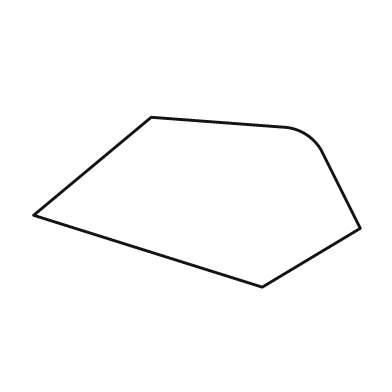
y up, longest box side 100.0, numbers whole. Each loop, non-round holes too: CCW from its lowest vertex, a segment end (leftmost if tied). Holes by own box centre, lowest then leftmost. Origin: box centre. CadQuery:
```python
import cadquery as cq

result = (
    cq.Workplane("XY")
    .moveTo(20.0, -26.0)
    .lineTo(50.0, -8.0)
    .lineTo(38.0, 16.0)
    .threePointArc((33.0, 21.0), (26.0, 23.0))
    .lineTo(-14.0, 26.0)
    .lineTo(-50.0, -4.0)
    .close()
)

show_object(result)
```